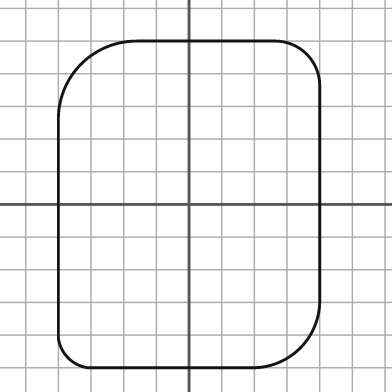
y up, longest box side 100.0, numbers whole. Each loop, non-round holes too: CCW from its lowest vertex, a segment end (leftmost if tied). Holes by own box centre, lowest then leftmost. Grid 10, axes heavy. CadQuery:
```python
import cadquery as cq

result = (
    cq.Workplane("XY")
    .moveTo(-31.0, -50.0)
    .lineTo(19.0, -50.0)
    .threePointArc((34.0, -44.0), (40.0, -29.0))
    .lineTo(40.0, 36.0)
    .threePointArc((36.0, 46.0), (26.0, 50.0))
    .lineTo(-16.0, 50.0)
    .threePointArc((-33.0, 43.0), (-40.0, 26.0))
    .lineTo(-40.0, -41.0)
    .threePointArc((-37.0, -47.0), (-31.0, -50.0))
    .close()
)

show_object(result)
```